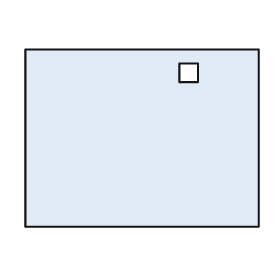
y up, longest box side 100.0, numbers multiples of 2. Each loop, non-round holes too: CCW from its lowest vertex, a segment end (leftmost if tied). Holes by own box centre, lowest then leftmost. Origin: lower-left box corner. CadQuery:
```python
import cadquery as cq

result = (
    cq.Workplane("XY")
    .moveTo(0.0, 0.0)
    .lineTo(100.0, 0.0)
    .lineTo(100.0, 76.0)
    .lineTo(0.0, 76.0)
    .close()
    .moveTo(66.0, 62.0)
    .lineTo(74.0, 62.0)
    .lineTo(74.0, 70.0)
    .lineTo(66.0, 70.0)
    .close()
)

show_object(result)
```